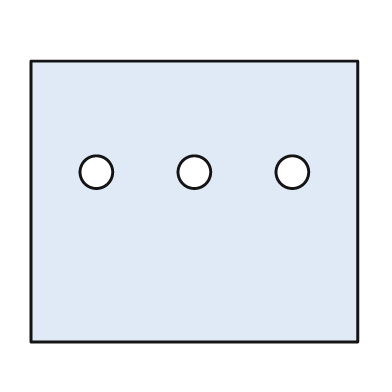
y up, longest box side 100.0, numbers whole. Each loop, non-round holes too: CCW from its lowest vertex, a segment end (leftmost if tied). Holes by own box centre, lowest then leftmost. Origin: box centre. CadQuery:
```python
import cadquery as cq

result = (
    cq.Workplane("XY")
    .moveTo(-50.0, -43.0)
    .lineTo(50.0, -43.0)
    .lineTo(50.0, 43.0)
    .lineTo(-50.0, 43.0)
    .close()
    .moveTo(-30.0, 9.0)
    .circle(5.0)
    .moveTo(0.0, 9.0)
    .circle(5.0)
    .moveTo(30.0, 9.0)
    .circle(5.0)
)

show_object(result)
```